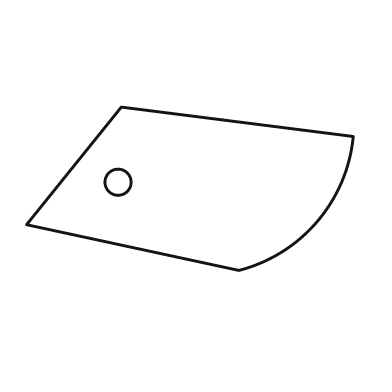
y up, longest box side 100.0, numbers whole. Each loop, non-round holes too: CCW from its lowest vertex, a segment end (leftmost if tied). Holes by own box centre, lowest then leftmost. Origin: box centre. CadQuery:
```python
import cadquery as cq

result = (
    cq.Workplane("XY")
    .moveTo(15.0, -25.0)
    .threePointArc((39.0, -10.0), (50.0, 16.0))
    .lineTo(-21.0, 25.0)
    .lineTo(-50.0, -11.0)
    .close()
    .moveTo(-22.0, 2.0)
    .circle(4.0)
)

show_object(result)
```